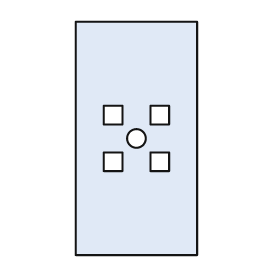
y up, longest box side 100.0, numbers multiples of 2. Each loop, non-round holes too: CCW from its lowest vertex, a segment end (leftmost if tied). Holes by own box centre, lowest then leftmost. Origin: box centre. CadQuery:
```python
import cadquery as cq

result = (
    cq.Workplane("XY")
    .moveTo(-26.0, -50.0)
    .lineTo(26.0, -50.0)
    .lineTo(26.0, 50.0)
    .lineTo(-26.0, 50.0)
    .close()
    .moveTo(-14.0, -14.0)
    .lineTo(-6.0, -14.0)
    .lineTo(-6.0, -6.0)
    .lineTo(-14.0, -6.0)
    .close()
    .moveTo(6.0, -14.0)
    .lineTo(14.0, -14.0)
    .lineTo(14.0, -6.0)
    .lineTo(6.0, -6.0)
    .close()
    .moveTo(0.0, 0.0)
    .circle(4.0)
    .moveTo(-14.0, 6.0)
    .lineTo(-6.0, 6.0)
    .lineTo(-6.0, 14.0)
    .lineTo(-14.0, 14.0)
    .close()
    .moveTo(6.0, 6.0)
    .lineTo(14.0, 6.0)
    .lineTo(14.0, 14.0)
    .lineTo(6.0, 14.0)
    .close()
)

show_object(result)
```